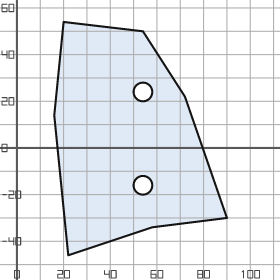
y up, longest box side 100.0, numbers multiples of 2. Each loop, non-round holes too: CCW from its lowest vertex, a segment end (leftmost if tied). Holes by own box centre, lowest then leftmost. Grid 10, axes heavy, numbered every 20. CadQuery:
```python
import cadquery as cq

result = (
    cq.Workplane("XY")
    .moveTo(22.0, -46.0)
    .lineTo(58.0, -34.0)
    .lineTo(90.0, -30.0)
    .lineTo(72.0, 22.0)
    .lineTo(54.0, 50.0)
    .lineTo(20.0, 54.0)
    .lineTo(16.0, 14.0)
    .close()
    .moveTo(54.0, -16.0)
    .circle(4.0)
    .moveTo(54.0, 24.0)
    .circle(4.0)
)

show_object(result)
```